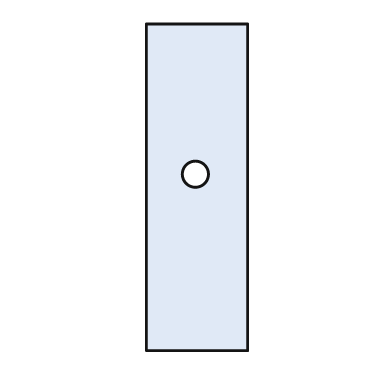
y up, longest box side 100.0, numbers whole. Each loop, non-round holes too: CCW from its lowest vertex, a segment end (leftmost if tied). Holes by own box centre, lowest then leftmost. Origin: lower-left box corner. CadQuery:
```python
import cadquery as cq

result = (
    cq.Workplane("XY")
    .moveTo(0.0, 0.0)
    .lineTo(31.0, 0.0)
    .lineTo(31.0, 100.0)
    .lineTo(0.0, 100.0)
    .close()
    .moveTo(15.0, 54.0)
    .circle(4.0)
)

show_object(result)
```